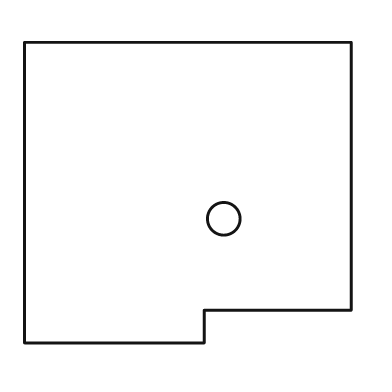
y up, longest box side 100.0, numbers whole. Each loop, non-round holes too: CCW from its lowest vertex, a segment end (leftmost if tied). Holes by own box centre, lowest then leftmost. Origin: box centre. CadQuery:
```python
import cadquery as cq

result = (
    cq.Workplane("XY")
    .moveTo(-50.0, -46.0)
    .lineTo(5.0, -46.0)
    .lineTo(5.0, -36.0)
    .lineTo(50.0, -36.0)
    .lineTo(50.0, 46.0)
    .lineTo(-50.0, 46.0)
    .close()
    .moveTo(11.0, -8.0)
    .circle(5.0)
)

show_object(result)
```